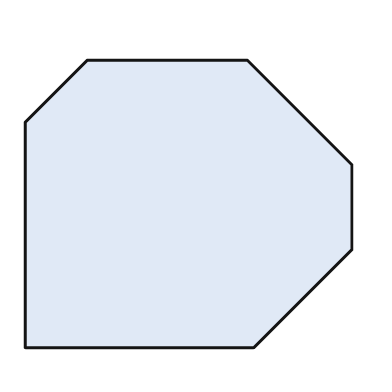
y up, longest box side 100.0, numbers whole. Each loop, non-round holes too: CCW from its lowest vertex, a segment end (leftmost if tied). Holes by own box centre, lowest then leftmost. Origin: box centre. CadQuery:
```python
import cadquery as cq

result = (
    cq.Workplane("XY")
    .moveTo(-50.0, -44.0)
    .lineTo(20.0, -44.0)
    .lineTo(50.0, -14.0)
    .lineTo(50.0, 12.0)
    .lineTo(18.0, 44.0)
    .lineTo(-31.0, 44.0)
    .lineTo(-50.0, 25.0)
    .close()
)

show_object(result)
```